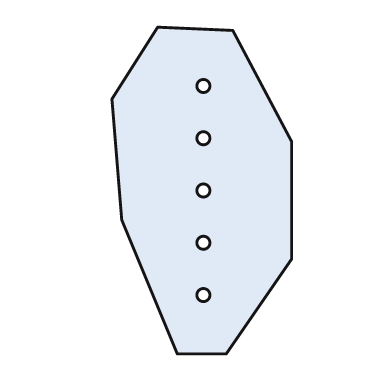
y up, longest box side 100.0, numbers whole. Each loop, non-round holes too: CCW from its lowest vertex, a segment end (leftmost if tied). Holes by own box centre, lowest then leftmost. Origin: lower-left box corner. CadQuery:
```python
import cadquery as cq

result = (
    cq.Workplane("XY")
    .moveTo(20.0, 0.0)
    .lineTo(35.0, 0.0)
    .lineTo(55.0, 29.0)
    .lineTo(55.0, 65.0)
    .lineTo(37.0, 99.0)
    .lineTo(14.0, 100.0)
    .lineTo(0.0, 78.0)
    .lineTo(3.0, 41.0)
    .close()
    .moveTo(28.0, 18.0)
    .circle(2.0)
    .moveTo(28.0, 34.0)
    .circle(2.0)
    .moveTo(28.0, 50.0)
    .circle(2.0)
    .moveTo(28.0, 66.0)
    .circle(2.0)
    .moveTo(28.0, 82.0)
    .circle(2.0)
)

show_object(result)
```